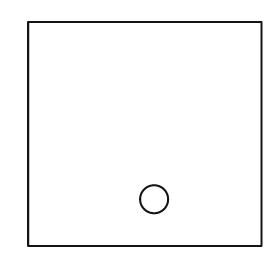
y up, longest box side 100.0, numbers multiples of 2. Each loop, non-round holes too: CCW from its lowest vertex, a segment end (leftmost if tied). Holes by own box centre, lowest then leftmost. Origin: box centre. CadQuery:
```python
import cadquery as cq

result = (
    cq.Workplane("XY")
    .moveTo(-50.0, -48.0)
    .lineTo(50.0, -48.0)
    .lineTo(50.0, 48.0)
    .lineTo(-50.0, 48.0)
    .close()
    .moveTo(4.0, -28.0)
    .circle(6.0)
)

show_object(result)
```